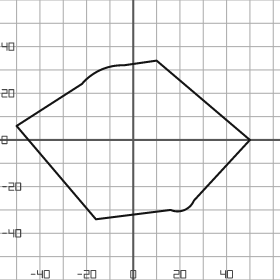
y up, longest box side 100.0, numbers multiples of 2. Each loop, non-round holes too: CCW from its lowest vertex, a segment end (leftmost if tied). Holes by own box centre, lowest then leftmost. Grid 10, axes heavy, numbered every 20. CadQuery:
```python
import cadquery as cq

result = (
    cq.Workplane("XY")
    .moveTo(-16.0, -34.0)
    .lineTo(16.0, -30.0)
    .threePointArc((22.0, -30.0), (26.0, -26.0))
    .lineTo(50.0, 0.0)
    .lineTo(10.0, 34.0)
    .lineTo(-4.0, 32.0)
    .threePointArc((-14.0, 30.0), (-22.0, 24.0))
    .lineTo(-50.0, 6.0)
    .close()
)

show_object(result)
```